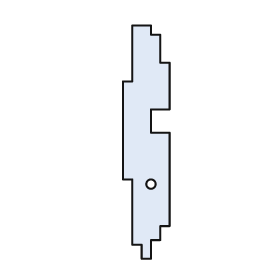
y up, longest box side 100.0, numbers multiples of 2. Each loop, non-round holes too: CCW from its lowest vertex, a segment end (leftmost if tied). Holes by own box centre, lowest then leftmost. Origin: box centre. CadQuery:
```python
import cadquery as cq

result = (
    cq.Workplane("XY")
    .moveTo(-2.0, -50.0)
    .lineTo(2.0, -50.0)
    .lineTo(2.0, -42.0)
    .lineTo(6.0, -42.0)
    .lineTo(6.0, -36.0)
    .lineTo(10.0, -36.0)
    .lineTo(10.0, 4.0)
    .lineTo(2.0, 4.0)
    .lineTo(2.0, 14.0)
    .lineTo(10.0, 14.0)
    .lineTo(10.0, 34.0)
    .lineTo(6.0, 34.0)
    .lineTo(6.0, 46.0)
    .lineTo(2.0, 46.0)
    .lineTo(2.0, 50.0)
    .lineTo(-6.0, 50.0)
    .lineTo(-6.0, 26.0)
    .lineTo(-10.0, 26.0)
    .lineTo(-10.0, -16.0)
    .lineTo(-6.0, -16.0)
    .lineTo(-6.0, -44.0)
    .lineTo(-2.0, -44.0)
    .close()
    .moveTo(2.0, -18.0)
    .circle(2.0)
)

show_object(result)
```